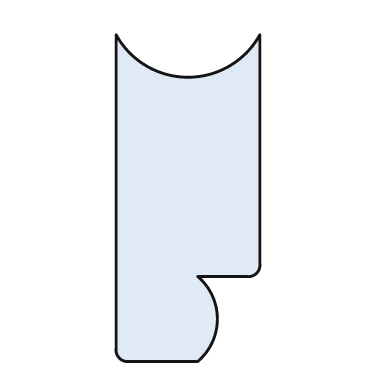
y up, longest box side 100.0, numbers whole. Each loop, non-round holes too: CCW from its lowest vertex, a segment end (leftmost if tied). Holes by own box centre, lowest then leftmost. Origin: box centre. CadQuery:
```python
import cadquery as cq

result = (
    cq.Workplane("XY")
    .moveTo(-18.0, -50.0)
    .lineTo(3.0, -50.0)
    .threePointArc((9.0, -37.0), (3.0, -24.0))
    .lineTo(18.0, -24.0)
    .threePointArc((21.0, -23.0), (22.0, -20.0))
    .lineTo(22.0, 50.0)
    .threePointArc((0.0, 37.0), (-22.0, 50.0))
    .lineTo(-22.0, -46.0)
    .threePointArc((-21.0, -49.0), (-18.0, -50.0))
    .close()
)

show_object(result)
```